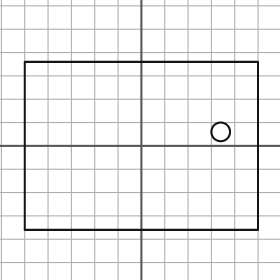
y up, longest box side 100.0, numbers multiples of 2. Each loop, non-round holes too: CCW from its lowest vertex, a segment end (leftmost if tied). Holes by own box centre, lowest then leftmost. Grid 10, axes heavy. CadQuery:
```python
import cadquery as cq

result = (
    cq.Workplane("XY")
    .moveTo(-50.0, -36.0)
    .lineTo(50.0, -36.0)
    .lineTo(50.0, 36.0)
    .lineTo(-50.0, 36.0)
    .close()
    .moveTo(34.0, 6.0)
    .circle(4.0)
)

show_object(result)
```